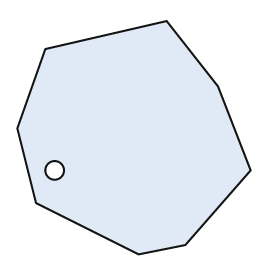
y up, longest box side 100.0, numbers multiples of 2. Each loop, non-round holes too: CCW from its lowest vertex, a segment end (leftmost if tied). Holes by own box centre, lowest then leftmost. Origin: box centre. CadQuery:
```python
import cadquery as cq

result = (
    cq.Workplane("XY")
    .moveTo(2.0, -50.0)
    .lineTo(22.0, -46.0)
    .lineTo(50.0, -14.0)
    .lineTo(36.0, 22.0)
    .lineTo(14.0, 50.0)
    .lineTo(-38.0, 38.0)
    .lineTo(-50.0, 4.0)
    .lineTo(-42.0, -28.0)
    .close()
    .moveTo(-34.0, -14.0)
    .circle(4.0)
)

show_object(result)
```